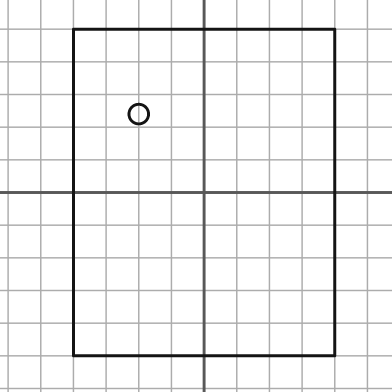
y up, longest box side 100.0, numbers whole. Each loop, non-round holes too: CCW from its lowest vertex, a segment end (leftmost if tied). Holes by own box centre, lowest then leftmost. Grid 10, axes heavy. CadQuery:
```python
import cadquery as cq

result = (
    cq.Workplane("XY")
    .moveTo(-40.0, -50.0)
    .lineTo(40.0, -50.0)
    .lineTo(40.0, 50.0)
    .lineTo(-40.0, 50.0)
    .close()
    .moveTo(-20.0, 24.0)
    .circle(3.0)
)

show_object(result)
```